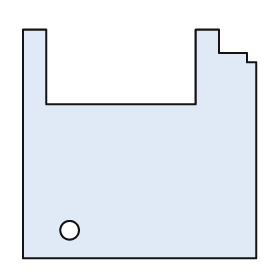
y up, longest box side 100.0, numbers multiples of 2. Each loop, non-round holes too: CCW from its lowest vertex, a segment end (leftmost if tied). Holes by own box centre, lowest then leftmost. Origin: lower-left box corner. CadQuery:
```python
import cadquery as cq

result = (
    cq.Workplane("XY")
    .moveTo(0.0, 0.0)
    .lineTo(100.0, 0.0)
    .lineTo(100.0, 84.0)
    .lineTo(96.0, 84.0)
    .lineTo(96.0, 88.0)
    .lineTo(84.0, 88.0)
    .lineTo(84.0, 98.0)
    .lineTo(74.0, 98.0)
    .lineTo(74.0, 66.0)
    .lineTo(10.0, 66.0)
    .lineTo(10.0, 98.0)
    .lineTo(0.0, 98.0)
    .close()
    .moveTo(20.0, 12.0)
    .circle(4.0)
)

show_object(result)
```